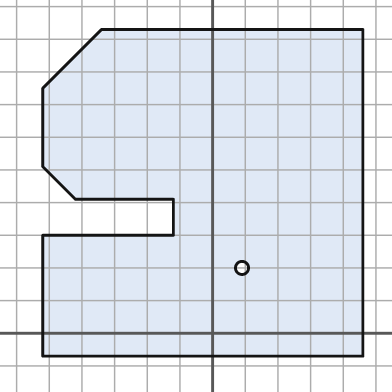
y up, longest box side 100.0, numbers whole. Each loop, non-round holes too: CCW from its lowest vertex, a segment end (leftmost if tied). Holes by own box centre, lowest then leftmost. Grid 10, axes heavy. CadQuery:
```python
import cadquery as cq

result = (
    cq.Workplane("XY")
    .moveTo(-52.0, -7.0)
    .lineTo(46.0, -7.0)
    .lineTo(46.0, 93.0)
    .lineTo(-34.0, 93.0)
    .lineTo(-52.0, 75.0)
    .lineTo(-52.0, 51.0)
    .lineTo(-42.0, 41.0)
    .lineTo(-12.0, 41.0)
    .lineTo(-12.0, 30.0)
    .lineTo(-52.0, 30.0)
    .close()
    .moveTo(9.0, 20.0)
    .circle(2.0)
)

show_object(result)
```